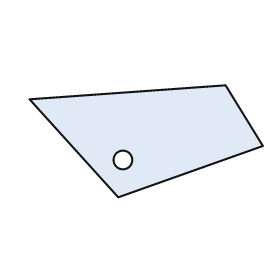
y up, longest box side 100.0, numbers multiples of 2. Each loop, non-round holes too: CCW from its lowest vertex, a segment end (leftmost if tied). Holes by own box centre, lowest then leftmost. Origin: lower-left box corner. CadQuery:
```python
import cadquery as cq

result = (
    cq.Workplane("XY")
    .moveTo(38.0, 0.0)
    .lineTo(100.0, 22.0)
    .lineTo(84.0, 48.0)
    .lineTo(0.0, 42.0)
    .close()
    .moveTo(40.0, 16.0)
    .circle(4.0)
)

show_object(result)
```